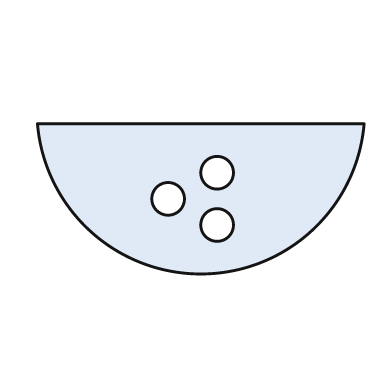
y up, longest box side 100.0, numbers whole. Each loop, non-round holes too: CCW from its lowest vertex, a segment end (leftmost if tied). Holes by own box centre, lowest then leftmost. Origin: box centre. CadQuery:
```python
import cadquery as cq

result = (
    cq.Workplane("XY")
    .moveTo(-50.0, 23.0)
    .threePointArc((0.0, -23.0), (50.0, 23.0))
    .close()
    .moveTo(5.0, -8.0)
    .circle(5.0)
    .moveTo(-10.0, 0.0)
    .circle(5.0)
    .moveTo(5.0, 8.0)
    .circle(5.0)
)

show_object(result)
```